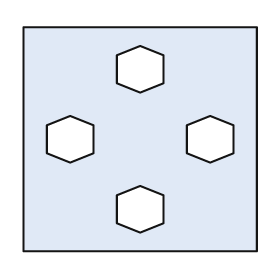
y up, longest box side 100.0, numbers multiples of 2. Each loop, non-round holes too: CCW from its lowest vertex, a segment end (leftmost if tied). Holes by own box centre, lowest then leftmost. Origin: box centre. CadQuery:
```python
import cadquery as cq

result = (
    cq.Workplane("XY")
    .moveTo(-50.0, -48.0)
    .lineTo(50.0, -48.0)
    .lineTo(50.0, 48.0)
    .lineTo(-50.0, 48.0)
    .close()
    .moveTo(0.0, -40.0)
    .lineTo(10.0, -36.0)
    .lineTo(10.0, -24.0)
    .lineTo(0.0, -20.0)
    .lineTo(-10.0, -24.0)
    .lineTo(-10.0, -36.0)
    .close()
    .moveTo(-30.0, -10.0)
    .lineTo(-20.0, -6.0)
    .lineTo(-20.0, 6.0)
    .lineTo(-30.0, 10.0)
    .lineTo(-40.0, 6.0)
    .lineTo(-40.0, -6.0)
    .close()
    .moveTo(30.0, -10.0)
    .lineTo(40.0, -6.0)
    .lineTo(40.0, 6.0)
    .lineTo(30.0, 10.0)
    .lineTo(20.0, 6.0)
    .lineTo(20.0, -6.0)
    .close()
    .moveTo(0.0, 20.0)
    .lineTo(10.0, 24.0)
    .lineTo(10.0, 36.0)
    .lineTo(0.0, 40.0)
    .lineTo(-10.0, 36.0)
    .lineTo(-10.0, 24.0)
    .close()
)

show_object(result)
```